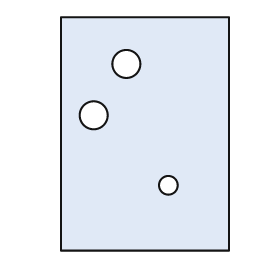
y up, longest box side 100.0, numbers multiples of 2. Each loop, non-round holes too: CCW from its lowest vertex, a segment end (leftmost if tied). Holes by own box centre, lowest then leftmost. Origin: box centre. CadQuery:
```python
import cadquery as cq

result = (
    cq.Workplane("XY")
    .moveTo(-36.0, -50.0)
    .lineTo(36.0, -50.0)
    .lineTo(36.0, 50.0)
    .lineTo(-36.0, 50.0)
    .close()
    .moveTo(10.0, -22.0)
    .circle(4.0)
    .moveTo(-22.0, 8.0)
    .circle(6.0)
    .moveTo(-8.0, 30.0)
    .circle(6.0)
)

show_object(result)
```